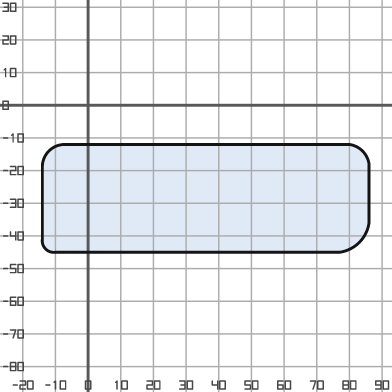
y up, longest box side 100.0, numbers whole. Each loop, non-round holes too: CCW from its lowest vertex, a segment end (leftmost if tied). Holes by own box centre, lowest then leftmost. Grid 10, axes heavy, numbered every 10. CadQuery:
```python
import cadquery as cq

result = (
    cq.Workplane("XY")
    .moveTo(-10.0, -45.0)
    .lineTo(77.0, -45.0)
    .threePointArc((83.0, -42.0), (86.0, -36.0))
    .lineTo(86.0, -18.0)
    .threePointArc((84.0, -14.0), (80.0, -12.0))
    .lineTo(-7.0, -12.0)
    .threePointArc((-12.0, -14.0), (-14.0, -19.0))
    .lineTo(-14.0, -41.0)
    .threePointArc((-13.0, -44.0), (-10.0, -45.0))
    .close()
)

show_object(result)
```